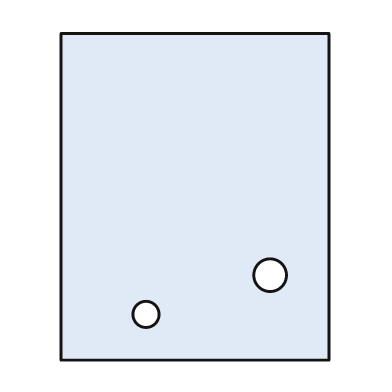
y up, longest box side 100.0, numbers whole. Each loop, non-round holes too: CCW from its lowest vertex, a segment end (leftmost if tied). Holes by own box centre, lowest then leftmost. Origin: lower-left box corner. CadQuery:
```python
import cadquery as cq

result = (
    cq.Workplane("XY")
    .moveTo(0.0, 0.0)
    .lineTo(82.0, 0.0)
    .lineTo(82.0, 100.0)
    .lineTo(0.0, 100.0)
    .close()
    .moveTo(26.0, 14.0)
    .circle(4.0)
    .moveTo(64.0, 26.0)
    .circle(5.0)
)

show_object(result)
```